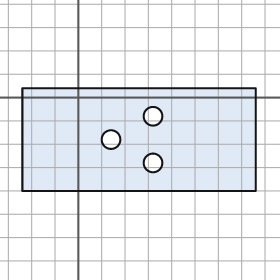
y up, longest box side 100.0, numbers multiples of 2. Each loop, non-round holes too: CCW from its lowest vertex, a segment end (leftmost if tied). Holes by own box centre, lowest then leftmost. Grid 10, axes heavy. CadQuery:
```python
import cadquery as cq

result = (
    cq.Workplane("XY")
    .moveTo(-24.0, -40.0)
    .lineTo(76.0, -40.0)
    .lineTo(76.0, 4.0)
    .lineTo(-24.0, 4.0)
    .close()
    .moveTo(32.0, -28.0)
    .circle(4.0)
    .moveTo(14.0, -18.0)
    .circle(4.0)
    .moveTo(32.0, -8.0)
    .circle(4.0)
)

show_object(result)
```